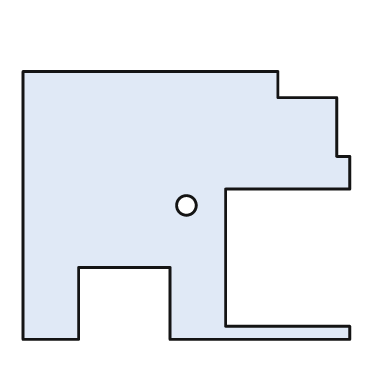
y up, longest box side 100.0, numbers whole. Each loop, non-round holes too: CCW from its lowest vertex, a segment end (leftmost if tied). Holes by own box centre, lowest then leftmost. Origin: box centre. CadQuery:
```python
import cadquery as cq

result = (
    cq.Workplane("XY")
    .moveTo(-50.0, -41.0)
    .lineTo(-33.0, -41.0)
    .lineTo(-33.0, -19.0)
    .lineTo(-5.0, -19.0)
    .lineTo(-5.0, -41.0)
    .lineTo(50.0, -41.0)
    .lineTo(50.0, -37.0)
    .lineTo(12.0, -37.0)
    .lineTo(12.0, 5.0)
    .lineTo(50.0, 5.0)
    .lineTo(50.0, 15.0)
    .lineTo(46.0, 15.0)
    .lineTo(46.0, 33.0)
    .lineTo(28.0, 33.0)
    .lineTo(28.0, 41.0)
    .lineTo(-50.0, 41.0)
    .close()
    .moveTo(0.0, 0.0)
    .circle(3.0)
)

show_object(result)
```